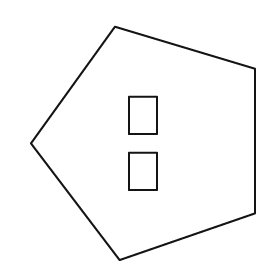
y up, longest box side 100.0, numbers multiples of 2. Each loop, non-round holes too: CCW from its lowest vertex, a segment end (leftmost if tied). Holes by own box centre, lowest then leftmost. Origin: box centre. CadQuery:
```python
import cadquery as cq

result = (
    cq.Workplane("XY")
    .moveTo(-10.0, -50.0)
    .lineTo(48.0, -30.0)
    .lineTo(48.0, 32.0)
    .lineTo(-12.0, 50.0)
    .lineTo(-48.0, 0.0)
    .close()
    .moveTo(-6.0, -20.0)
    .lineTo(6.0, -20.0)
    .lineTo(6.0, -4.0)
    .lineTo(-6.0, -4.0)
    .close()
    .moveTo(-6.0, 4.0)
    .lineTo(6.0, 4.0)
    .lineTo(6.0, 20.0)
    .lineTo(-6.0, 20.0)
    .close()
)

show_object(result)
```